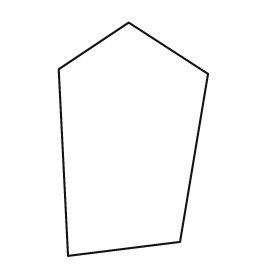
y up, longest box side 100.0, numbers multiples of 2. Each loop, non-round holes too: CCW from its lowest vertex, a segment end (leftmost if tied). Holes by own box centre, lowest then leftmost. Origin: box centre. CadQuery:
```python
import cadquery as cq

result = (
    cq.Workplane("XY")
    .moveTo(-28.0, -50.0)
    .lineTo(20.0, -44.0)
    .lineTo(32.0, 28.0)
    .lineTo(-2.0, 50.0)
    .lineTo(-32.0, 30.0)
    .close()
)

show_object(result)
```